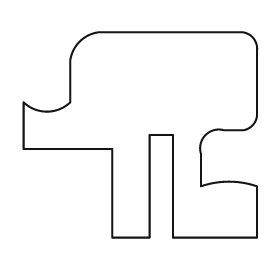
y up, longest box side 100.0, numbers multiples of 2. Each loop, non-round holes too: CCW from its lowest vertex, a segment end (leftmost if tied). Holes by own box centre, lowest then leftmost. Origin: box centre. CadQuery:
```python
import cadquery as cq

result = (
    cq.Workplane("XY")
    .moveTo(-12.0, -44.0)
    .lineTo(4.0, -44.0)
    .lineTo(4.0, 0.0)
    .lineTo(14.0, 0.0)
    .lineTo(14.0, -44.0)
    .lineTo(50.0, -44.0)
    .lineTo(50.0, -22.0)
    .threePointArc((38.0, -20.0), (26.0, -22.0))
    .lineTo(26.0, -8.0)
    .threePointArc((28.0, 0.0), (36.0, 2.0))
    .lineTo(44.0, 2.0)
    .threePointArc((48.0, 4.0), (50.0, 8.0))
    .lineTo(50.0, 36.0)
    .threePointArc((48.0, 42.0), (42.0, 44.0))
    .lineTo(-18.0, 44.0)
    .threePointArc((-26.0, 40.0), (-30.0, 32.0))
    .lineTo(-30.0, 14.0)
    .threePointArc((-40.0, 10.0), (-50.0, 14.0))
    .lineTo(-50.0, -6.0)
    .lineTo(-12.0, -6.0)
    .close()
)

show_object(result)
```